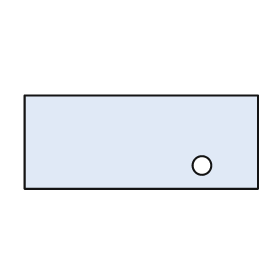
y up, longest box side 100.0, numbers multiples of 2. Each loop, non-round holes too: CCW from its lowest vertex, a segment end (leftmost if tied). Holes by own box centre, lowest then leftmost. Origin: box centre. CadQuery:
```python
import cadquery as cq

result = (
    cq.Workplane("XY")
    .moveTo(-50.0, -20.0)
    .lineTo(50.0, -20.0)
    .lineTo(50.0, 20.0)
    .lineTo(-50.0, 20.0)
    .close()
    .moveTo(26.0, -10.0)
    .circle(4.0)
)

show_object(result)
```